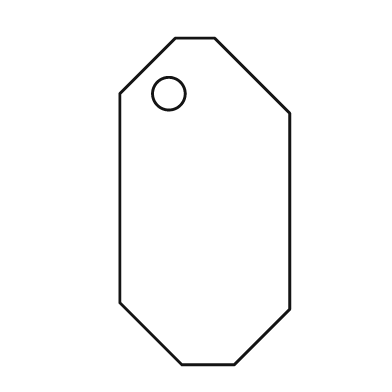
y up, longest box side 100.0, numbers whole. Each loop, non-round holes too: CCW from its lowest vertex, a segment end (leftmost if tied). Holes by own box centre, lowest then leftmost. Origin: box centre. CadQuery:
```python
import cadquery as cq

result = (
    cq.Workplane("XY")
    .moveTo(-7.0, -50.0)
    .lineTo(9.0, -50.0)
    .lineTo(26.0, -33.0)
    .lineTo(26.0, 27.0)
    .lineTo(3.0, 50.0)
    .lineTo(-9.0, 50.0)
    .lineTo(-26.0, 33.0)
    .lineTo(-26.0, -31.0)
    .close()
    .moveTo(-11.0, 33.0)
    .circle(5.0)
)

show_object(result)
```